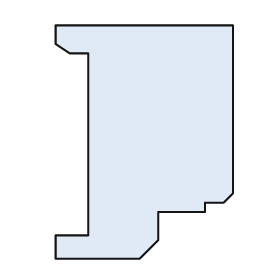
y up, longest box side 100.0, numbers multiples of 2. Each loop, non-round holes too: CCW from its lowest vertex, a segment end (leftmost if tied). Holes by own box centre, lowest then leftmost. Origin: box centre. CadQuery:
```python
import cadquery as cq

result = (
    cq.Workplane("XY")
    .moveTo(-38.0, -50.0)
    .lineTo(-2.0, -50.0)
    .lineTo(6.0, -42.0)
    .lineTo(6.0, -30.0)
    .lineTo(26.0, -30.0)
    .lineTo(26.0, -26.0)
    .lineTo(34.0, -26.0)
    .lineTo(38.0, -22.0)
    .lineTo(38.0, 50.0)
    .lineTo(-38.0, 50.0)
    .lineTo(-38.0, 42.0)
    .lineTo(-32.0, 38.0)
    .lineTo(-24.0, 38.0)
    .lineTo(-24.0, -40.0)
    .lineTo(-38.0, -40.0)
    .close()
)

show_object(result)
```